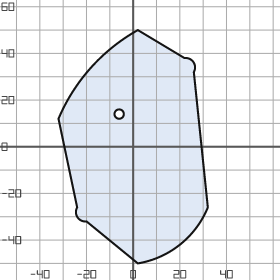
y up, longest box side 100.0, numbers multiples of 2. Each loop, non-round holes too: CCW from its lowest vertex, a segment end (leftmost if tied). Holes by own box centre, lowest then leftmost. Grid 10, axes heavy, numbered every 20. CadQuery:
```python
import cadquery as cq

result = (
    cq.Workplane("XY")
    .moveTo(2.0, -50.0)
    .threePointArc((20.0, -42.0), (32.0, -26.0))
    .lineTo(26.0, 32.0)
    .threePointArc((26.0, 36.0), (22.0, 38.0))
    .lineTo(2.0, 50.0)
    .threePointArc((-18.0, 34.0), (-32.0, 12.0))
    .lineTo(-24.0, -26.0)
    .threePointArc((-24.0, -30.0), (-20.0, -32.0))
    .close()
    .moveTo(-6.0, 14.0)
    .circle(2.0)
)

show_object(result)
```